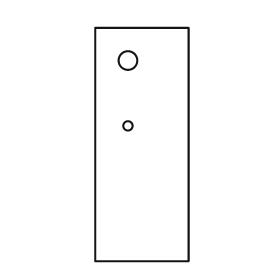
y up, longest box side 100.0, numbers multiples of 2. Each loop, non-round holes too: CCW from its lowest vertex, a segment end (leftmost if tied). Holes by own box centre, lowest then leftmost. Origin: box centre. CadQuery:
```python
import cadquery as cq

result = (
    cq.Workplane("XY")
    .moveTo(-20.0, -50.0)
    .lineTo(20.0, -50.0)
    .lineTo(20.0, 50.0)
    .lineTo(-20.0, 50.0)
    .close()
    .moveTo(-6.0, 8.0)
    .circle(2.0)
    .moveTo(-6.0, 36.0)
    .circle(4.0)
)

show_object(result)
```